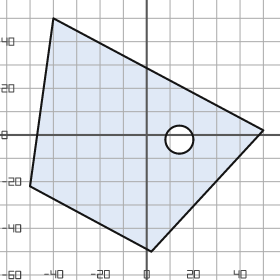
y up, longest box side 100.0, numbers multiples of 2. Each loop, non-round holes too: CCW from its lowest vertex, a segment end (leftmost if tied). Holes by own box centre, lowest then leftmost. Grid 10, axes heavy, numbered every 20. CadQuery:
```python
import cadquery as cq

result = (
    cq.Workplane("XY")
    .moveTo(2.0, -50.0)
    .lineTo(50.0, 2.0)
    .lineTo(-40.0, 50.0)
    .lineTo(-50.0, -22.0)
    .close()
    .moveTo(14.0, -2.0)
    .circle(6.0)
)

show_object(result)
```